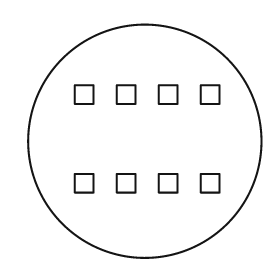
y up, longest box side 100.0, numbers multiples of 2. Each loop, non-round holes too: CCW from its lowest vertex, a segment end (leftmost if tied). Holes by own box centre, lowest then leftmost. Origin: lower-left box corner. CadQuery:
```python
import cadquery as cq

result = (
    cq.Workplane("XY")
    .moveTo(50.0, 50.0)
    .circle(50.0)
    .moveTo(20.0, 28.0)
    .lineTo(28.0, 28.0)
    .lineTo(28.0, 36.0)
    .lineTo(20.0, 36.0)
    .close()
    .moveTo(38.0, 28.0)
    .lineTo(46.0, 28.0)
    .lineTo(46.0, 36.0)
    .lineTo(38.0, 36.0)
    .close()
    .moveTo(56.0, 28.0)
    .lineTo(64.0, 28.0)
    .lineTo(64.0, 36.0)
    .lineTo(56.0, 36.0)
    .close()
    .moveTo(74.0, 28.0)
    .lineTo(82.0, 28.0)
    .lineTo(82.0, 36.0)
    .lineTo(74.0, 36.0)
    .close()
    .moveTo(20.0, 66.0)
    .lineTo(28.0, 66.0)
    .lineTo(28.0, 74.0)
    .lineTo(20.0, 74.0)
    .close()
    .moveTo(38.0, 66.0)
    .lineTo(46.0, 66.0)
    .lineTo(46.0, 74.0)
    .lineTo(38.0, 74.0)
    .close()
    .moveTo(56.0, 66.0)
    .lineTo(64.0, 66.0)
    .lineTo(64.0, 74.0)
    .lineTo(56.0, 74.0)
    .close()
    .moveTo(74.0, 66.0)
    .lineTo(82.0, 66.0)
    .lineTo(82.0, 74.0)
    .lineTo(74.0, 74.0)
    .close()
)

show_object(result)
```